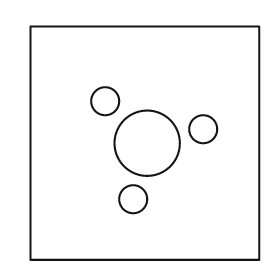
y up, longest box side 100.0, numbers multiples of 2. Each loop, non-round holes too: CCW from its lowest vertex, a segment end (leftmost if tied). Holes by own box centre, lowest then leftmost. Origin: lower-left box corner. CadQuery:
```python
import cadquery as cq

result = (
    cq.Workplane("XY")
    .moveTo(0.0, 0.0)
    .lineTo(98.0, 0.0)
    .lineTo(98.0, 100.0)
    .lineTo(0.0, 100.0)
    .close()
    .moveTo(44.0, 26.0)
    .circle(6.0)
    .moveTo(50.0, 50.0)
    .circle(14.0)
    .moveTo(74.0, 56.0)
    .circle(6.0)
    .moveTo(32.0, 68.0)
    .circle(6.0)
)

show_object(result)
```